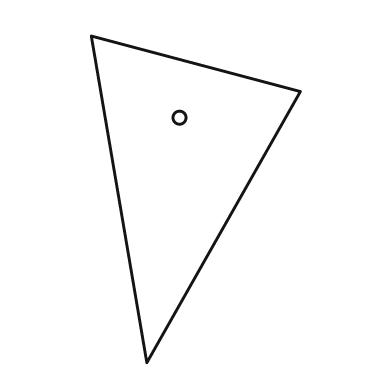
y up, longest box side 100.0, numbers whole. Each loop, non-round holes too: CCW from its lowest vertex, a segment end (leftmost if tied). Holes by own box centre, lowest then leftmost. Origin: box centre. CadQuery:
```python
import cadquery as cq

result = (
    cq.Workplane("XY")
    .moveTo(-15.0, -50.0)
    .lineTo(32.0, 33.0)
    .lineTo(-32.0, 50.0)
    .close()
    .moveTo(-5.0, 25.0)
    .circle(2.0)
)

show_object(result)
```